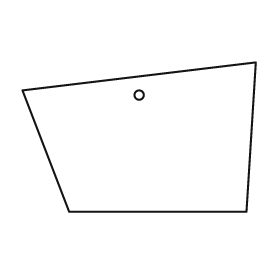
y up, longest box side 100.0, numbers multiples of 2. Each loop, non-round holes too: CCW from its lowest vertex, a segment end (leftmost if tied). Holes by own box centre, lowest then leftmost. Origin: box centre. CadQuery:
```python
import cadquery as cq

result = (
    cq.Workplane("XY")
    .moveTo(-30.0, -32.0)
    .lineTo(46.0, -32.0)
    .lineTo(50.0, 32.0)
    .lineTo(-50.0, 20.0)
    .close()
    .moveTo(0.0, 18.0)
    .circle(2.0)
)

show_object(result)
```